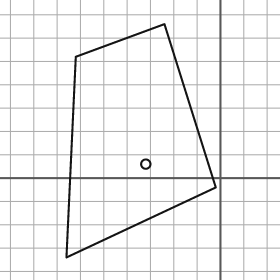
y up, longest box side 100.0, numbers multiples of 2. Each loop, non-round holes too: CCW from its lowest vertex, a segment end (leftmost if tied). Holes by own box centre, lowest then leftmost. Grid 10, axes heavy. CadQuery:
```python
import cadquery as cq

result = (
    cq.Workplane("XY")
    .moveTo(-66.0, -34.0)
    .lineTo(-2.0, -4.0)
    .lineTo(-24.0, 66.0)
    .lineTo(-62.0, 52.0)
    .close()
    .moveTo(-32.0, 6.0)
    .circle(2.0)
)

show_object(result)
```